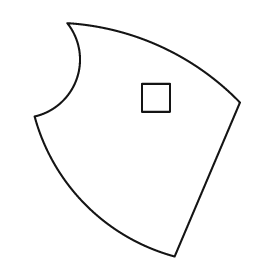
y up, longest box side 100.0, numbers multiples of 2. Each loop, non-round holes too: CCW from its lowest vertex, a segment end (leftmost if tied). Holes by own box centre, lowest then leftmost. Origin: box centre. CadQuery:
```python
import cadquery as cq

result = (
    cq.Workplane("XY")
    .moveTo(16.0, -50.0)
    .lineTo(44.0, 16.0)
    .threePointArc((10.0, 40.0), (-30.0, 50.0))
    .threePointArc((-26.0, 26.0), (-44.0, 10.0))
    .threePointArc((-22.0, -28.0), (16.0, -50.0))
    .close()
    .moveTo(2.0, 12.0)
    .lineTo(14.0, 12.0)
    .lineTo(14.0, 24.0)
    .lineTo(2.0, 24.0)
    .close()
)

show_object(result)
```